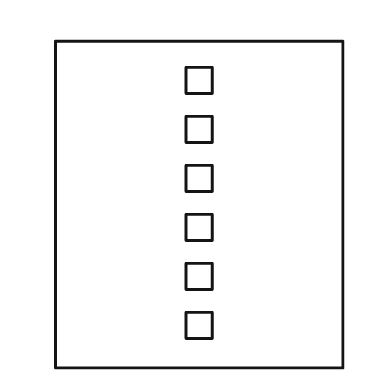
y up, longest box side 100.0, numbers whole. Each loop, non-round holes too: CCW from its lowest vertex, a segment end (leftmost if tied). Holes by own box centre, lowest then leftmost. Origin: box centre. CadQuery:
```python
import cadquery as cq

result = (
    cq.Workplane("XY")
    .moveTo(-44.0, -50.0)
    .lineTo(44.0, -50.0)
    .lineTo(44.0, 50.0)
    .lineTo(-44.0, 50.0)
    .close()
    .moveTo(-4.0, -41.0)
    .lineTo(4.0, -41.0)
    .lineTo(4.0, -33.0)
    .lineTo(-4.0, -33.0)
    .close()
    .moveTo(-4.0, -26.0)
    .lineTo(4.0, -26.0)
    .lineTo(4.0, -18.0)
    .lineTo(-4.0, -18.0)
    .close()
    .moveTo(-4.0, -11.0)
    .lineTo(4.0, -11.0)
    .lineTo(4.0, -3.0)
    .lineTo(-4.0, -3.0)
    .close()
    .moveTo(-4.0, 4.0)
    .lineTo(4.0, 4.0)
    .lineTo(4.0, 12.0)
    .lineTo(-4.0, 12.0)
    .close()
    .moveTo(-4.0, 19.0)
    .lineTo(4.0, 19.0)
    .lineTo(4.0, 27.0)
    .lineTo(-4.0, 27.0)
    .close()
    .moveTo(-4.0, 34.0)
    .lineTo(4.0, 34.0)
    .lineTo(4.0, 42.0)
    .lineTo(-4.0, 42.0)
    .close()
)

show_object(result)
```